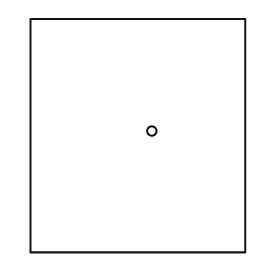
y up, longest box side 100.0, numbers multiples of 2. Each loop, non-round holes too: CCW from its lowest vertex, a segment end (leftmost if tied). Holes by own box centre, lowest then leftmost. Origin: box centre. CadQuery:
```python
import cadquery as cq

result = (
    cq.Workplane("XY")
    .moveTo(-46.0, -50.0)
    .lineTo(46.0, -50.0)
    .lineTo(46.0, 50.0)
    .lineTo(-46.0, 50.0)
    .close()
    .moveTo(6.0, 2.0)
    .circle(2.0)
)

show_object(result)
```